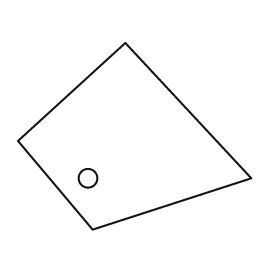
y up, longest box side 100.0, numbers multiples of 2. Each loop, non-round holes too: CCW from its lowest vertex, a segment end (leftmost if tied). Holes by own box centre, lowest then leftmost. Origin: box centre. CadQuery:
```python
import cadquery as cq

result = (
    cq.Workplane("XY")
    .moveTo(-18.0, -40.0)
    .lineTo(50.0, -18.0)
    .lineTo(-4.0, 40.0)
    .lineTo(-50.0, -2.0)
    .close()
    .moveTo(-20.0, -18.0)
    .circle(4.0)
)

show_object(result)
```